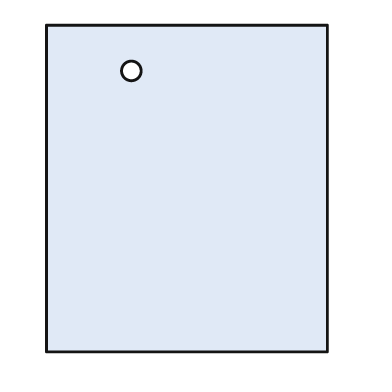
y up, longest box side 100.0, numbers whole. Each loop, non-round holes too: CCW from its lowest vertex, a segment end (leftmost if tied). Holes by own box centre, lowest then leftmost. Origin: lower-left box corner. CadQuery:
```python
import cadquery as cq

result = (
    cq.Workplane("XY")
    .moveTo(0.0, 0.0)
    .lineTo(86.0, 0.0)
    .lineTo(86.0, 100.0)
    .lineTo(0.0, 100.0)
    .close()
    .moveTo(26.0, 86.0)
    .circle(3.0)
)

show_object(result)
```